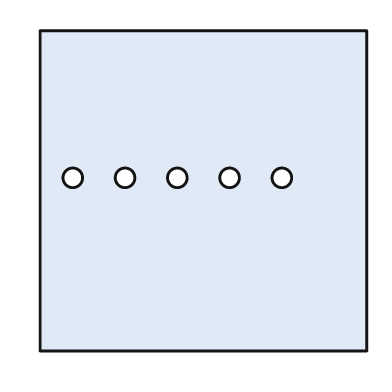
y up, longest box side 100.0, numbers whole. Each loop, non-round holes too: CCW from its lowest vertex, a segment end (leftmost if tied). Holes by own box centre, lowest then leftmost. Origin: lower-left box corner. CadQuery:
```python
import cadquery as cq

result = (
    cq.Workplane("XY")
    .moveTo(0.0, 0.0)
    .lineTo(100.0, 0.0)
    .lineTo(100.0, 98.0)
    .lineTo(0.0, 98.0)
    .close()
    .moveTo(10.0, 53.0)
    .circle(3.0)
    .moveTo(26.0, 53.0)
    .circle(3.0)
    .moveTo(42.0, 53.0)
    .circle(3.0)
    .moveTo(58.0, 53.0)
    .circle(3.0)
    .moveTo(74.0, 53.0)
    .circle(3.0)
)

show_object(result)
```